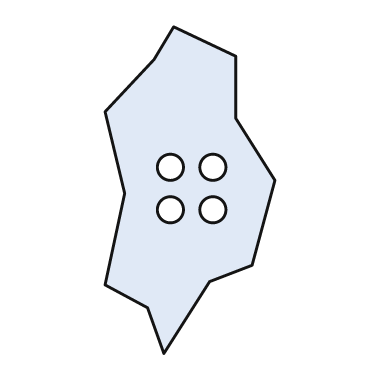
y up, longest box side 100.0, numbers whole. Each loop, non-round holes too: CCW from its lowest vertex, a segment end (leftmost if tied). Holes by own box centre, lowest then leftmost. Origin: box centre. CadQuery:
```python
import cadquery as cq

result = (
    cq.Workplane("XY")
    .moveTo(-8.0, -50.0)
    .lineTo(6.0, -28.0)
    .lineTo(19.0, -23.0)
    .lineTo(26.0, 3.0)
    .lineTo(14.0, 22.0)
    .lineTo(14.0, 41.0)
    .lineTo(-5.0, 50.0)
    .lineTo(-11.0, 40.0)
    .lineTo(-26.0, 24.0)
    .lineTo(-20.0, -1.0)
    .lineTo(-26.0, -29.0)
    .lineTo(-13.0, -36.0)
    .close()
    .moveTo(-6.0, -6.0)
    .circle(4.0)
    .moveTo(7.0, -6.0)
    .circle(4.0)
    .moveTo(-6.0, 7.0)
    .circle(4.0)
    .moveTo(7.0, 7.0)
    .circle(4.0)
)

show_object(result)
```